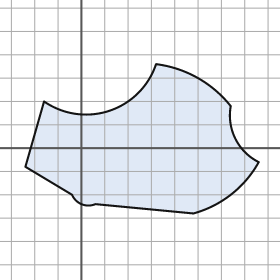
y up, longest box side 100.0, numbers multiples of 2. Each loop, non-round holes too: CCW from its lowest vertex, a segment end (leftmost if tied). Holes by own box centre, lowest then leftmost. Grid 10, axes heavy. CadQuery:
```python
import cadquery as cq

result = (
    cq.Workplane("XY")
    .moveTo(48.0, -28.0)
    .threePointArc((64.0, -20.0), (76.0, -6.0))
    .threePointArc((66.0, 4.0), (64.0, 18.0))
    .threePointArc((50.0, 30.0), (32.0, 36.0))
    .threePointArc((12.0, 16.0), (-16.0, 20.0))
    .lineTo(-24.0, -8.0)
    .lineTo(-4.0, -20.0)
    .threePointArc((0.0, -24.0), (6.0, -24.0))
    .close()
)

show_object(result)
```